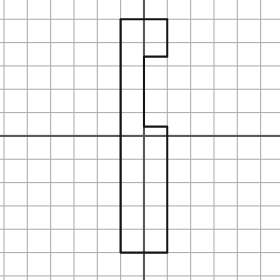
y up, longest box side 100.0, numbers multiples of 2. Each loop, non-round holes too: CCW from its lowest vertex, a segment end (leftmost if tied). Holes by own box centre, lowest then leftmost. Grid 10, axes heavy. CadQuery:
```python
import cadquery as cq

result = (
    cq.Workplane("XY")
    .moveTo(-10.0, -50.0)
    .lineTo(10.0, -50.0)
    .lineTo(10.0, 4.0)
    .lineTo(0.0, 4.0)
    .lineTo(0.0, 34.0)
    .lineTo(10.0, 34.0)
    .lineTo(10.0, 50.0)
    .lineTo(-10.0, 50.0)
    .close()
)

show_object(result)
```